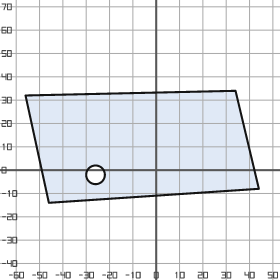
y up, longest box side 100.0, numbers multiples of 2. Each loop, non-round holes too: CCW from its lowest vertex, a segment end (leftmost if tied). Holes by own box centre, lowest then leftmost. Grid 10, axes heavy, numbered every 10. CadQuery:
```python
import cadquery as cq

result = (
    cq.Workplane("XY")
    .moveTo(-46.0, -14.0)
    .lineTo(44.0, -8.0)
    .lineTo(34.0, 34.0)
    .lineTo(-56.0, 32.0)
    .close()
    .moveTo(-26.0, -2.0)
    .circle(4.0)
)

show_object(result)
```